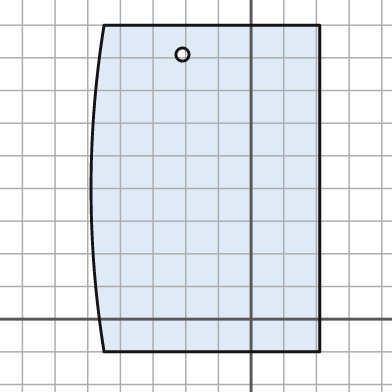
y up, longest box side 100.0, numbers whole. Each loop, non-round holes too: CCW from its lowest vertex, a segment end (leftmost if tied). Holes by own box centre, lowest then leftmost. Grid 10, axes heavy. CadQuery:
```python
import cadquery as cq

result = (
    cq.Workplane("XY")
    .moveTo(-45.0, -10.0)
    .lineTo(21.0, -10.0)
    .lineTo(21.0, 90.0)
    .lineTo(-45.0, 90.0)
    .threePointArc((-49.0, 40.0), (-45.0, -10.0))
    .close()
    .moveTo(-21.0, 81.0)
    .circle(2.0)
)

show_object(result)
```